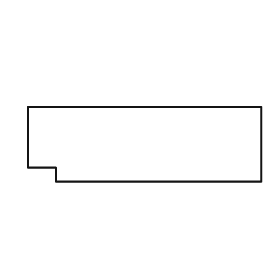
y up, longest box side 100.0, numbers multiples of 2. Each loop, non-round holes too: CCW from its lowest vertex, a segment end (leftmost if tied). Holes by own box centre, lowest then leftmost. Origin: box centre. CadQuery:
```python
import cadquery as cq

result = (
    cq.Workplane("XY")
    .moveTo(-38.0, -16.0)
    .lineTo(50.0, -16.0)
    .lineTo(50.0, 16.0)
    .lineTo(-50.0, 16.0)
    .lineTo(-50.0, -10.0)
    .lineTo(-38.0, -10.0)
    .close()
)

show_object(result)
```